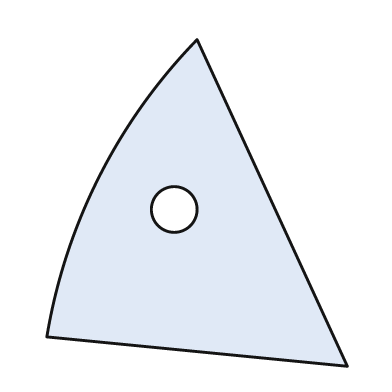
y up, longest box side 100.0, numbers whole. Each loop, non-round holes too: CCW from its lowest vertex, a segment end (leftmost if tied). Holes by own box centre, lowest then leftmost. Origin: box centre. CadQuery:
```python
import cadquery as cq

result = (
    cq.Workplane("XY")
    .moveTo(46.0, -50.0)
    .lineTo(0.0, 50.0)
    .threePointArc((-30.0, 8.0), (-46.0, -41.0))
    .close()
    .moveTo(-7.0, -2.0)
    .circle(7.0)
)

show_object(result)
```